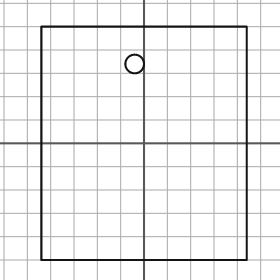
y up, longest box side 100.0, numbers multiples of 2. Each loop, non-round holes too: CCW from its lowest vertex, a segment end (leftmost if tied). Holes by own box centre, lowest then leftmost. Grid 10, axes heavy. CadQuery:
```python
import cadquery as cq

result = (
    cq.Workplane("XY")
    .moveTo(-44.0, -50.0)
    .lineTo(44.0, -50.0)
    .lineTo(44.0, 50.0)
    .lineTo(-44.0, 50.0)
    .close()
    .moveTo(-4.0, 34.0)
    .circle(4.0)
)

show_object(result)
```